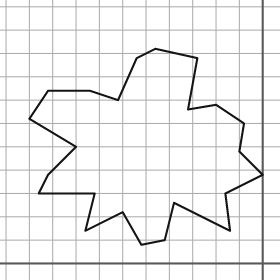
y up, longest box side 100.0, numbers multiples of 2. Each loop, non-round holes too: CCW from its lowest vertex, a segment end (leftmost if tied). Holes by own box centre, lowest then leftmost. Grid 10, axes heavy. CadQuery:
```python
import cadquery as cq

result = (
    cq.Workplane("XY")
    .moveTo(-52.0, 8.0)
    .lineTo(-42.0, 10.0)
    .lineTo(-38.0, 26.0)
    .lineTo(-14.0, 14.0)
    .lineTo(-16.0, 30.0)
    .lineTo(0.0, 38.0)
    .lineTo(-10.0, 48.0)
    .lineTo(-8.0, 60.0)
    .lineTo(-20.0, 68.0)
    .lineTo(-32.0, 66.0)
    .lineTo(-28.0, 88.0)
    .lineTo(-46.0, 92.0)
    .lineTo(-54.0, 88.0)
    .lineTo(-62.0, 70.0)
    .lineTo(-74.0, 74.0)
    .lineTo(-92.0, 74.0)
    .lineTo(-100.0, 62.0)
    .lineTo(-80.0, 50.0)
    .lineTo(-92.0, 38.0)
    .lineTo(-96.0, 30.0)
    .lineTo(-72.0, 30.0)
    .lineTo(-76.0, 14.0)
    .lineTo(-60.0, 22.0)
    .close()
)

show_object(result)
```